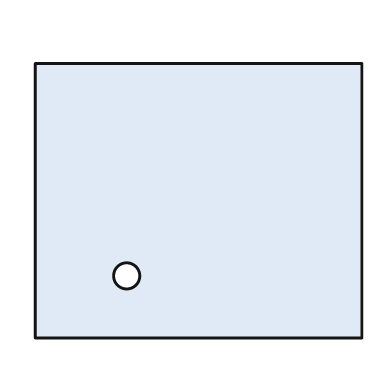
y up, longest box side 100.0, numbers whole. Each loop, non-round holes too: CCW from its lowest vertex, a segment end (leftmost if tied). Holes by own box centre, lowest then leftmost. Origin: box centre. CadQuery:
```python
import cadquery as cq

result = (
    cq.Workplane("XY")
    .moveTo(-50.0, -42.0)
    .lineTo(50.0, -42.0)
    .lineTo(50.0, 42.0)
    .lineTo(-50.0, 42.0)
    .close()
    .moveTo(-22.0, -23.0)
    .circle(4.0)
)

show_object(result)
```